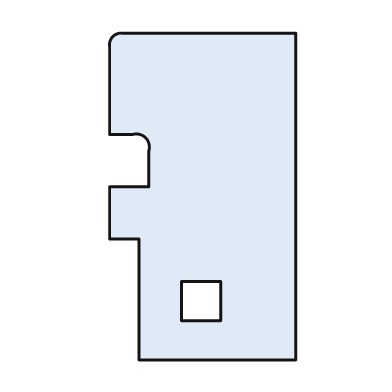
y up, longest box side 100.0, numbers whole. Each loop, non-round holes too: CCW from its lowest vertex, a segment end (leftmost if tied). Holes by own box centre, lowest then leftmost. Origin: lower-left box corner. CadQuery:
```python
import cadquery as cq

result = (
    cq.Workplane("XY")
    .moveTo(9.0, 0.0)
    .lineTo(57.0, 0.0)
    .lineTo(57.0, 100.0)
    .lineTo(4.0, 100.0)
    .threePointArc((1.0, 99.0), (0.0, 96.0))
    .lineTo(0.0, 69.0)
    .lineTo(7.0, 69.0)
    .threePointArc((11.0, 68.0), (12.0, 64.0))
    .lineTo(12.0, 53.0)
    .lineTo(0.0, 53.0)
    .lineTo(0.0, 37.0)
    .lineTo(9.0, 37.0)
    .close()
    .moveTo(22.0, 12.0)
    .lineTo(34.0, 12.0)
    .lineTo(34.0, 24.0)
    .lineTo(22.0, 24.0)
    .close()
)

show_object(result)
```